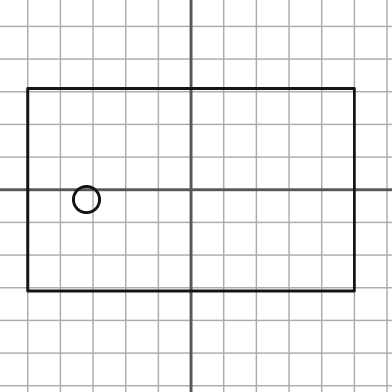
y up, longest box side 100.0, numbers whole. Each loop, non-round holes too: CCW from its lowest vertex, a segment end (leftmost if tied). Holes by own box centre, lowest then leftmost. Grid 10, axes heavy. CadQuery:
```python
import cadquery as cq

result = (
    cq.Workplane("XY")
    .moveTo(-50.0, -31.0)
    .lineTo(50.0, -31.0)
    .lineTo(50.0, 31.0)
    .lineTo(-50.0, 31.0)
    .close()
    .moveTo(-32.0, -3.0)
    .circle(4.0)
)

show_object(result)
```